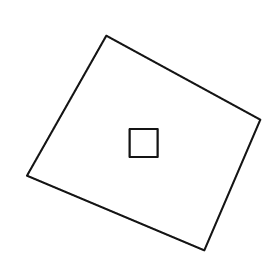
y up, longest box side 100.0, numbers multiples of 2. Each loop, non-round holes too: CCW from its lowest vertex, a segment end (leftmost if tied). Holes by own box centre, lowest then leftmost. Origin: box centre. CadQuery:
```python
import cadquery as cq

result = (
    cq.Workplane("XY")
    .moveTo(26.0, -46.0)
    .lineTo(50.0, 10.0)
    .lineTo(-16.0, 46.0)
    .lineTo(-50.0, -14.0)
    .close()
    .moveTo(-6.0, -6.0)
    .lineTo(6.0, -6.0)
    .lineTo(6.0, 6.0)
    .lineTo(-6.0, 6.0)
    .close()
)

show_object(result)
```